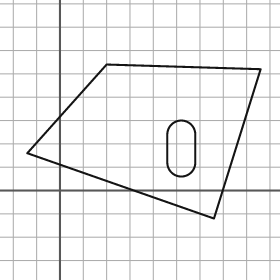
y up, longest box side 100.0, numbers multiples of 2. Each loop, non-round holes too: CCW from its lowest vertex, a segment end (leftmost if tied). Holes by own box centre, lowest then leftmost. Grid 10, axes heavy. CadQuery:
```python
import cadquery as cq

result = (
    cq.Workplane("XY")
    .moveTo(66.0, -12.0)
    .lineTo(86.0, 52.0)
    .lineTo(20.0, 54.0)
    .lineTo(-14.0, 16.0)
    .close()
    .moveTo(46.0, 12.0)
    .threePointArc((52.0, 6.0), (58.0, 12.0))
    .lineTo(58.0, 24.0)
    .threePointArc((52.0, 30.0), (46.0, 24.0))
    .close()
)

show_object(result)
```